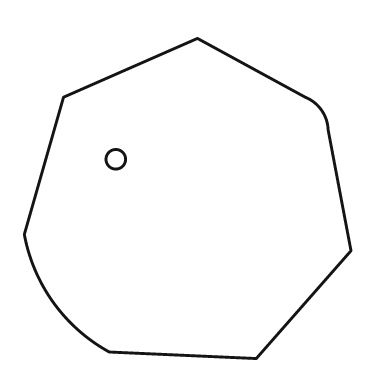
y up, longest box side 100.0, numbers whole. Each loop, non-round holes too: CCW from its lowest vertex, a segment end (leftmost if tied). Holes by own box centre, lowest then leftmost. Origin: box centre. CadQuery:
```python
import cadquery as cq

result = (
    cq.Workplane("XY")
    .moveTo(21.0, -49.0)
    .lineTo(50.0, -16.0)
    .lineTo(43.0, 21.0)
    .threePointArc((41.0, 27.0), (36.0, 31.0))
    .lineTo(3.0, 49.0)
    .lineTo(-38.0, 31.0)
    .lineTo(-50.0, -11.0)
    .threePointArc((-41.0, -32.0), (-24.0, -47.0))
    .close()
    .moveTo(-22.0, 12.0)
    .circle(3.0)
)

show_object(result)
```